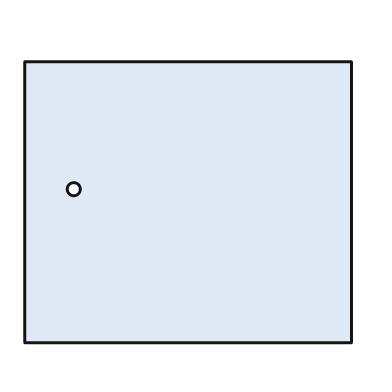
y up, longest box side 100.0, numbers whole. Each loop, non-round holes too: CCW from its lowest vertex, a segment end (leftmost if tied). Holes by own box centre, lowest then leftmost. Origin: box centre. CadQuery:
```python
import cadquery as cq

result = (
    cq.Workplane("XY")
    .moveTo(-50.0, -43.0)
    .lineTo(50.0, -43.0)
    .lineTo(50.0, 43.0)
    .lineTo(-50.0, 43.0)
    .close()
    .moveTo(-35.0, 4.0)
    .circle(2.0)
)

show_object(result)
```